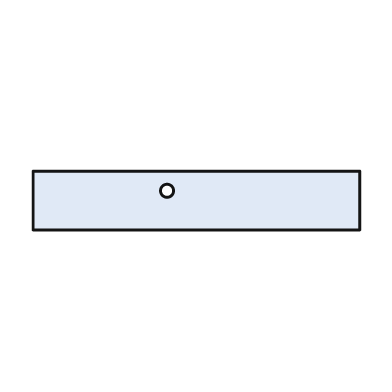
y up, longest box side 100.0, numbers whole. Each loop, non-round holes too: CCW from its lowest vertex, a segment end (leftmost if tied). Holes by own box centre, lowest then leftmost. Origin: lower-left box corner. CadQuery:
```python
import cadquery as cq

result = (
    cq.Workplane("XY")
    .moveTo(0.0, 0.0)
    .lineTo(100.0, 0.0)
    .lineTo(100.0, 18.0)
    .lineTo(0.0, 18.0)
    .close()
    .moveTo(41.0, 12.0)
    .circle(2.0)
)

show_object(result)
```